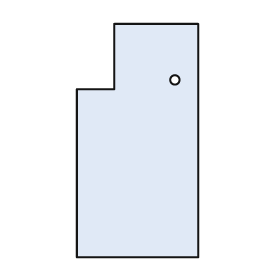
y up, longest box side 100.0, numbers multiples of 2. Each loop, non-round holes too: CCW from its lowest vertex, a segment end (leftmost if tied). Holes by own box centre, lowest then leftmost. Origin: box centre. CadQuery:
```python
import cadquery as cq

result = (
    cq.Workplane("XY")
    .moveTo(-26.0, -50.0)
    .lineTo(26.0, -50.0)
    .lineTo(26.0, 50.0)
    .lineTo(-10.0, 50.0)
    .lineTo(-10.0, 22.0)
    .lineTo(-26.0, 22.0)
    .close()
    .moveTo(16.0, 26.0)
    .circle(2.0)
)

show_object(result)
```